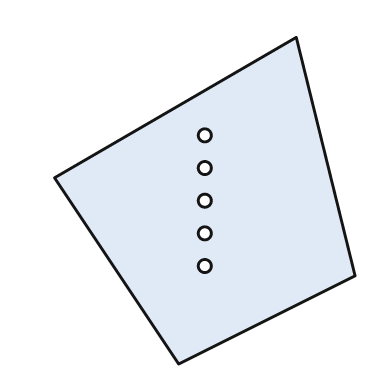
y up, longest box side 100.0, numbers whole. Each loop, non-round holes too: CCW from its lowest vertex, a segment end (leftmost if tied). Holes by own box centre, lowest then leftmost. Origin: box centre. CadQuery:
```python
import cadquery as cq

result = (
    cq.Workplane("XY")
    .moveTo(-8.0, -50.0)
    .lineTo(46.0, -23.0)
    .lineTo(28.0, 50.0)
    .lineTo(-46.0, 7.0)
    .close()
    .moveTo(0.0, -20.0)
    .circle(2.0)
    .moveTo(0.0, -10.0)
    .circle(2.0)
    .moveTo(0.0, 0.0)
    .circle(2.0)
    .moveTo(0.0, 10.0)
    .circle(2.0)
    .moveTo(0.0, 20.0)
    .circle(2.0)
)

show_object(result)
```